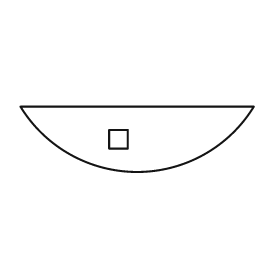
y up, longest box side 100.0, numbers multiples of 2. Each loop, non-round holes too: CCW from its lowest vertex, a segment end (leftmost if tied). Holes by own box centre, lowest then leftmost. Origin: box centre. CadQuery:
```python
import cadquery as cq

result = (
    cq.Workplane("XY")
    .moveTo(-50.0, 14.0)
    .threePointArc((0.0, -14.0), (50.0, 14.0))
    .close()
    .moveTo(-12.0, -4.0)
    .lineTo(-4.0, -4.0)
    .lineTo(-4.0, 4.0)
    .lineTo(-12.0, 4.0)
    .close()
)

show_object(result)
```